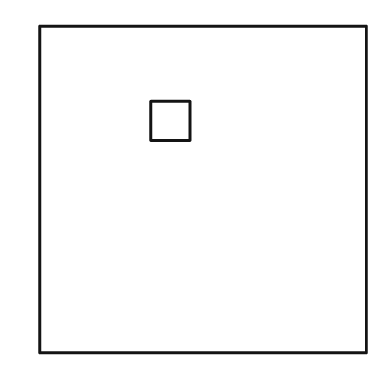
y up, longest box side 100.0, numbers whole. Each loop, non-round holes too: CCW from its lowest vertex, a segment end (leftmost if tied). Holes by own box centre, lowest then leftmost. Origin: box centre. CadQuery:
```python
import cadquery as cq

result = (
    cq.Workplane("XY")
    .moveTo(-50.0, -50.0)
    .lineTo(50.0, -50.0)
    .lineTo(50.0, 50.0)
    .lineTo(-50.0, 50.0)
    .close()
    .moveTo(-16.0, 15.0)
    .lineTo(-4.0, 15.0)
    .lineTo(-4.0, 27.0)
    .lineTo(-16.0, 27.0)
    .close()
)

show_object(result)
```